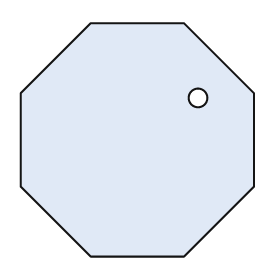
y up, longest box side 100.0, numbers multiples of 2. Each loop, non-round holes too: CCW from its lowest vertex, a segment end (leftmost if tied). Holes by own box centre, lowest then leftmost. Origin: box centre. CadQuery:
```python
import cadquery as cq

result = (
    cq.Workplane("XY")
    .moveTo(-20.0, -50.0)
    .lineTo(20.0, -50.0)
    .lineTo(50.0, -20.0)
    .lineTo(50.0, 20.0)
    .lineTo(20.0, 50.0)
    .lineTo(-20.0, 50.0)
    .lineTo(-50.0, 20.0)
    .lineTo(-50.0, -20.0)
    .close()
    .moveTo(26.0, 18.0)
    .circle(4.0)
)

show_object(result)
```